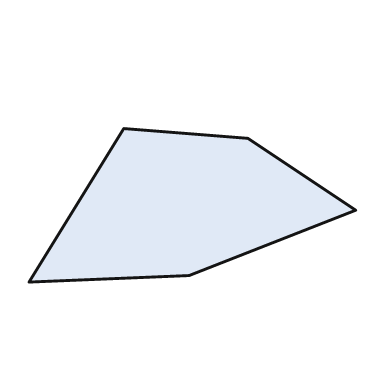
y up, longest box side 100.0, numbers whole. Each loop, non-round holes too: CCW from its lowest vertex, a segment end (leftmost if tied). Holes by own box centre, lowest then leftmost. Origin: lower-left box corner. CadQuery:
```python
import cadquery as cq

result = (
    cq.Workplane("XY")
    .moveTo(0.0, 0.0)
    .lineTo(49.0, 2.0)
    .lineTo(100.0, 22.0)
    .lineTo(67.0, 44.0)
    .lineTo(29.0, 47.0)
    .close()
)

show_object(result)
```